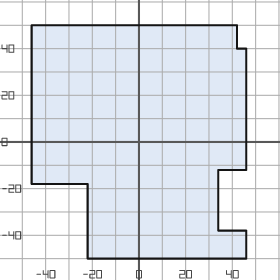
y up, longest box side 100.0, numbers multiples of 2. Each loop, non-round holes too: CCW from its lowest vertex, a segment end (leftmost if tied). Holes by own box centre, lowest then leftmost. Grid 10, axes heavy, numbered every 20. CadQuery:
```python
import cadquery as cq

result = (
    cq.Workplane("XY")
    .moveTo(-22.0, -50.0)
    .lineTo(46.0, -50.0)
    .lineTo(46.0, -38.0)
    .lineTo(34.0, -38.0)
    .lineTo(34.0, -12.0)
    .lineTo(46.0, -12.0)
    .lineTo(46.0, 40.0)
    .lineTo(42.0, 40.0)
    .lineTo(42.0, 50.0)
    .lineTo(-46.0, 50.0)
    .lineTo(-46.0, -18.0)
    .lineTo(-22.0, -18.0)
    .close()
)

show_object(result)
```